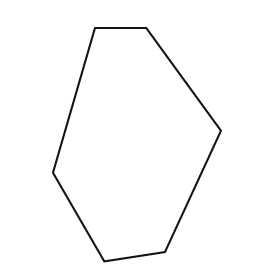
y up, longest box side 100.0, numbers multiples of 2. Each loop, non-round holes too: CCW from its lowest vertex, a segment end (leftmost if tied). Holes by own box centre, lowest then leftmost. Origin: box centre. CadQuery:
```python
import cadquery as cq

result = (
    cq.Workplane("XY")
    .moveTo(-14.0, -50.0)
    .lineTo(12.0, -46.0)
    .lineTo(36.0, 6.0)
    .lineTo(4.0, 50.0)
    .lineTo(-18.0, 50.0)
    .lineTo(-36.0, -12.0)
    .close()
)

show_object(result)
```